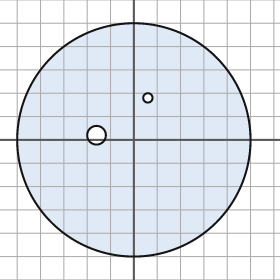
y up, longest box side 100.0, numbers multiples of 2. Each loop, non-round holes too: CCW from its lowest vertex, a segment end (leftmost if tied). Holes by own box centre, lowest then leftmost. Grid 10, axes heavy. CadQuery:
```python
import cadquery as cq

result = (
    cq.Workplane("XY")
    .moveTo(0.0, 0.0)
    .circle(50.0)
    .moveTo(-16.0, 2.0)
    .circle(4.0)
    .moveTo(6.0, 18.0)
    .circle(2.0)
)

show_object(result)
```